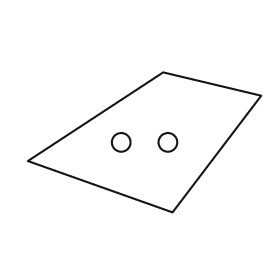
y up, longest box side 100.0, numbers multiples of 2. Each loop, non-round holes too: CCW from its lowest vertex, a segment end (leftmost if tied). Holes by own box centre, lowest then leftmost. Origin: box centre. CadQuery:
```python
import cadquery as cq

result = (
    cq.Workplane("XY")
    .moveTo(12.0, -30.0)
    .lineTo(50.0, 20.0)
    .lineTo(8.0, 30.0)
    .lineTo(-50.0, -8.0)
    .close()
    .moveTo(-10.0, 0.0)
    .circle(4.0)
    .moveTo(10.0, 0.0)
    .circle(4.0)
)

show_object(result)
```